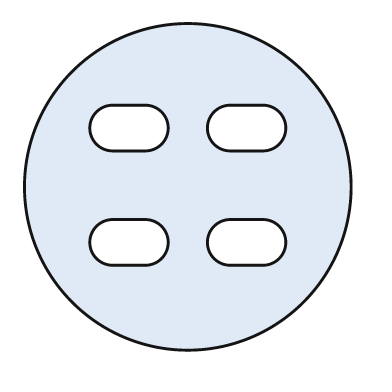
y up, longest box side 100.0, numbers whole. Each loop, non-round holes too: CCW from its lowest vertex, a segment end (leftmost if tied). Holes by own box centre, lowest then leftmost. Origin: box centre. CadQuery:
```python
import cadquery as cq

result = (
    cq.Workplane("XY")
    .moveTo(0.0, 0.0)
    .circle(50.0)
    .moveTo(-23.0, -24.0)
    .lineTo(-13.0, -24.0)
    .threePointArc((-6.0, -17.0), (-13.0, -10.0))
    .lineTo(-23.0, -10.0)
    .threePointArc((-30.0, -17.0), (-23.0, -24.0))
    .close()
    .moveTo(13.0, -24.0)
    .lineTo(23.0, -24.0)
    .threePointArc((30.0, -17.0), (23.0, -10.0))
    .lineTo(13.0, -10.0)
    .threePointArc((6.0, -17.0), (13.0, -24.0))
    .close()
    .moveTo(-23.0, 11.0)
    .lineTo(-13.0, 11.0)
    .threePointArc((-6.0, 18.0), (-13.0, 25.0))
    .lineTo(-23.0, 25.0)
    .threePointArc((-30.0, 18.0), (-23.0, 11.0))
    .close()
    .moveTo(13.0, 11.0)
    .lineTo(23.0, 11.0)
    .threePointArc((30.0, 18.0), (23.0, 25.0))
    .lineTo(13.0, 25.0)
    .threePointArc((6.0, 18.0), (13.0, 11.0))
    .close()
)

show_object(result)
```